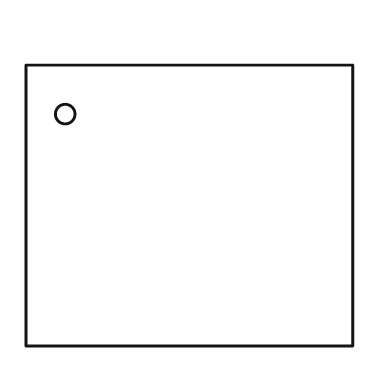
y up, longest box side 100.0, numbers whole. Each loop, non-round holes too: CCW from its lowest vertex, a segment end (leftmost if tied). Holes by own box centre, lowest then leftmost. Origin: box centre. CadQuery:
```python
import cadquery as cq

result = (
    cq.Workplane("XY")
    .moveTo(-50.0, -43.0)
    .lineTo(50.0, -43.0)
    .lineTo(50.0, 43.0)
    .lineTo(-50.0, 43.0)
    .close()
    .moveTo(-38.0, 28.0)
    .circle(3.0)
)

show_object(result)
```